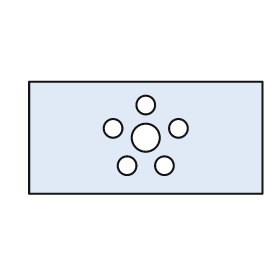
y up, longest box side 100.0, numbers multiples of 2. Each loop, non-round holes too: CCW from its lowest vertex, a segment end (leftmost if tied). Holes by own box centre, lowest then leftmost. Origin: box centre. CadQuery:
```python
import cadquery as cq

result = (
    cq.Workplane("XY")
    .moveTo(-50.0, -24.0)
    .lineTo(50.0, -24.0)
    .lineTo(50.0, 24.0)
    .lineTo(-50.0, 24.0)
    .close()
    .moveTo(-8.0, -12.0)
    .circle(4.0)
    .moveTo(8.0, -12.0)
    .circle(4.0)
    .moveTo(0.0, 0.0)
    .circle(6.0)
    .moveTo(-14.0, 4.0)
    .circle(4.0)
    .moveTo(14.0, 4.0)
    .circle(4.0)
    .moveTo(0.0, 14.0)
    .circle(4.0)
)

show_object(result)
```